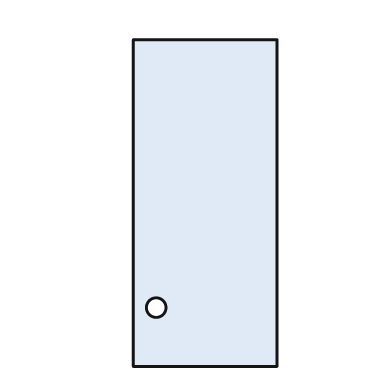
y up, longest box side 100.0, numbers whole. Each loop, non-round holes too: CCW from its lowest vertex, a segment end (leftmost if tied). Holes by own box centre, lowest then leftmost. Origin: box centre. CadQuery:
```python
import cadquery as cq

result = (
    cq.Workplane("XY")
    .moveTo(-22.0, -50.0)
    .lineTo(22.0, -50.0)
    .lineTo(22.0, 50.0)
    .lineTo(-22.0, 50.0)
    .close()
    .moveTo(-15.0, -32.0)
    .circle(3.0)
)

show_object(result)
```